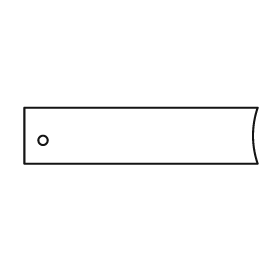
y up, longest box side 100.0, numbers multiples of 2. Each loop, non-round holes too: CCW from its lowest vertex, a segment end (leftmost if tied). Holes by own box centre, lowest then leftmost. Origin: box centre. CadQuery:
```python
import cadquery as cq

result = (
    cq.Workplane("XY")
    .moveTo(-50.0, -12.0)
    .lineTo(50.0, -12.0)
    .threePointArc((48.0, 0.0), (50.0, 12.0))
    .lineTo(-50.0, 12.0)
    .close()
    .moveTo(-42.0, -2.0)
    .circle(2.0)
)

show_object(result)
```